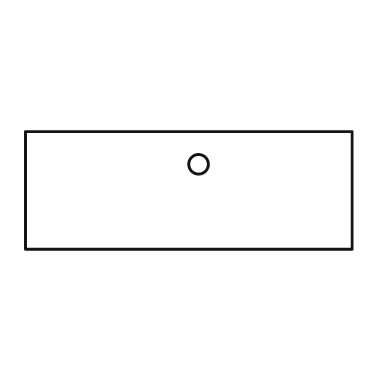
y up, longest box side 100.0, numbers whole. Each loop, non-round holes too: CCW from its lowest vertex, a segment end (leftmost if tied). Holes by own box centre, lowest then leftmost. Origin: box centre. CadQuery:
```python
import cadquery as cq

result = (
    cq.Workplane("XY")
    .moveTo(-50.0, -18.0)
    .lineTo(50.0, -18.0)
    .lineTo(50.0, 18.0)
    .lineTo(-50.0, 18.0)
    .close()
    .moveTo(3.0, 8.0)
    .circle(3.0)
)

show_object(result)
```